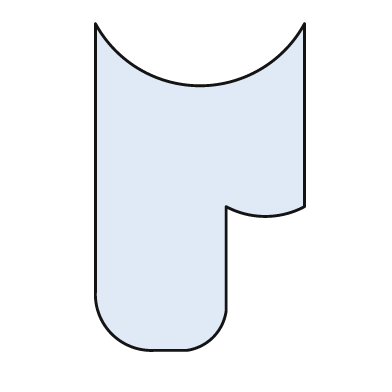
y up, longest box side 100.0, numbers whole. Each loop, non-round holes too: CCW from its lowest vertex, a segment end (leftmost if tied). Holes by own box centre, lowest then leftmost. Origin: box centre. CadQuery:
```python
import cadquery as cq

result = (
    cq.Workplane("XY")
    .moveTo(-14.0, -50.0)
    .lineTo(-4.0, -50.0)
    .threePointArc((4.0, -46.0), (8.0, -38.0))
    .lineTo(8.0, -6.0)
    .threePointArc((20.0, -9.0), (32.0, -6.0))
    .lineTo(32.0, 50.0)
    .threePointArc((0.0, 31.0), (-32.0, 50.0))
    .lineTo(-32.0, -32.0)
    .threePointArc((-27.0, -45.0), (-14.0, -50.0))
    .close()
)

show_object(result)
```